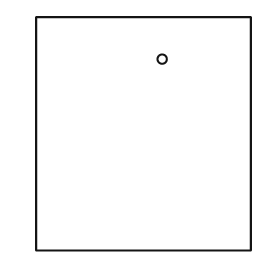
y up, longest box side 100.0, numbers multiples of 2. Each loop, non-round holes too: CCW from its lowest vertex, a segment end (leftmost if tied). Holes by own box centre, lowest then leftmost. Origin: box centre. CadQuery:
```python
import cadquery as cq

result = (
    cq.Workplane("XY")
    .moveTo(-46.0, -50.0)
    .lineTo(46.0, -50.0)
    .lineTo(46.0, 50.0)
    .lineTo(-46.0, 50.0)
    .close()
    .moveTo(8.0, 32.0)
    .circle(2.0)
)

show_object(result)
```